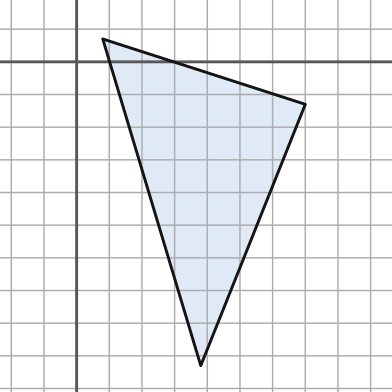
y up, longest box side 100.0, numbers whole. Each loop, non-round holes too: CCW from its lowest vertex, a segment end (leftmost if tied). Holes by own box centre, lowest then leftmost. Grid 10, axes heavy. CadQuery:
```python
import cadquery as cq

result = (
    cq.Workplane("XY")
    .moveTo(38.0, -93.0)
    .lineTo(70.0, -13.0)
    .lineTo(8.0, 7.0)
    .close()
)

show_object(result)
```